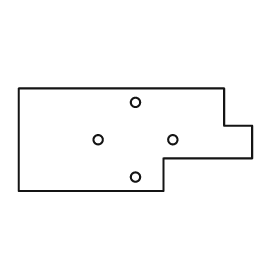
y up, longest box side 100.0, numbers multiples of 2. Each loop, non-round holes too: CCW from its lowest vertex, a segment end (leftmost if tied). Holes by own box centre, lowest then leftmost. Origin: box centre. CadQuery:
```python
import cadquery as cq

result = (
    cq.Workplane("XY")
    .moveTo(-50.0, -22.0)
    .lineTo(12.0, -22.0)
    .lineTo(12.0, -8.0)
    .lineTo(50.0, -8.0)
    .lineTo(50.0, 6.0)
    .lineTo(38.0, 6.0)
    .lineTo(38.0, 22.0)
    .lineTo(-50.0, 22.0)
    .close()
    .moveTo(0.0, -16.0)
    .circle(2.0)
    .moveTo(-16.0, 0.0)
    .circle(2.0)
    .moveTo(16.0, 0.0)
    .circle(2.0)
    .moveTo(0.0, 16.0)
    .circle(2.0)
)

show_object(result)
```